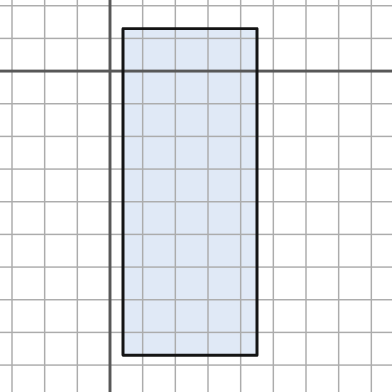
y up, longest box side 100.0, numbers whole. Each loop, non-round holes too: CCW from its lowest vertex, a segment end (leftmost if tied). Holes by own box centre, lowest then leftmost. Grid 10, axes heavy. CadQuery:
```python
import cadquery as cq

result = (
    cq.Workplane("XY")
    .moveTo(4.0, -87.0)
    .lineTo(45.0, -87.0)
    .lineTo(45.0, 13.0)
    .lineTo(4.0, 13.0)
    .close()
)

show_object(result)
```